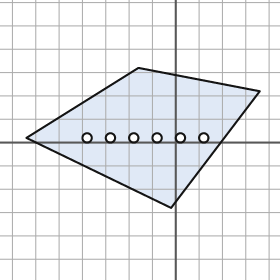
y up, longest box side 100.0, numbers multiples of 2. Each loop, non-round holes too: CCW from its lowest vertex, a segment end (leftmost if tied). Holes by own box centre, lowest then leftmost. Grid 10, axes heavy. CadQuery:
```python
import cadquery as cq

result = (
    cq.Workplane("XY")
    .moveTo(-2.0, -28.0)
    .lineTo(36.0, 22.0)
    .lineTo(-16.0, 32.0)
    .lineTo(-64.0, 2.0)
    .close()
    .moveTo(-38.0, 2.0)
    .circle(2.0)
    .moveTo(-28.0, 2.0)
    .circle(2.0)
    .moveTo(-18.0, 2.0)
    .circle(2.0)
    .moveTo(-8.0, 2.0)
    .circle(2.0)
    .moveTo(2.0, 2.0)
    .circle(2.0)
    .moveTo(12.0, 2.0)
    .circle(2.0)
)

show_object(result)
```